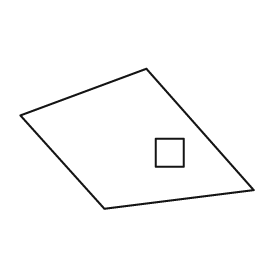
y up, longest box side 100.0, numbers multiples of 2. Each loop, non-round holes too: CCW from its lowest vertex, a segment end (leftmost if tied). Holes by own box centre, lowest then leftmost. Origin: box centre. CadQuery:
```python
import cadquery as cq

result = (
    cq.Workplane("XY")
    .moveTo(-14.0, -30.0)
    .lineTo(50.0, -22.0)
    .lineTo(4.0, 30.0)
    .lineTo(-50.0, 10.0)
    .close()
    .moveTo(8.0, -12.0)
    .lineTo(20.0, -12.0)
    .lineTo(20.0, 0.0)
    .lineTo(8.0, 0.0)
    .close()
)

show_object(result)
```